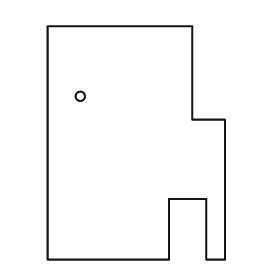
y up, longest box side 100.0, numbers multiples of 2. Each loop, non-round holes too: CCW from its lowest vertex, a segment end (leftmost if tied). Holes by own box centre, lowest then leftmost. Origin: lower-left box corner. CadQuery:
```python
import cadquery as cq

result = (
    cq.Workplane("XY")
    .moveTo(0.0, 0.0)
    .lineTo(52.0, 0.0)
    .lineTo(52.0, 26.0)
    .lineTo(68.0, 26.0)
    .lineTo(68.0, 0.0)
    .lineTo(76.0, 0.0)
    .lineTo(76.0, 60.0)
    .lineTo(62.0, 60.0)
    .lineTo(62.0, 100.0)
    .lineTo(0.0, 100.0)
    .close()
    .moveTo(14.0, 70.0)
    .circle(2.0)
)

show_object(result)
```